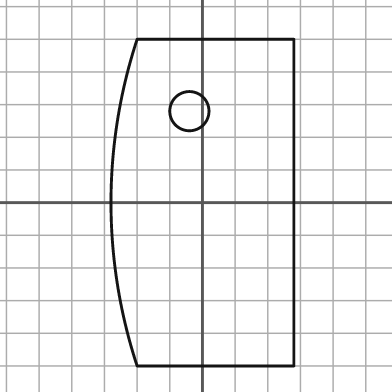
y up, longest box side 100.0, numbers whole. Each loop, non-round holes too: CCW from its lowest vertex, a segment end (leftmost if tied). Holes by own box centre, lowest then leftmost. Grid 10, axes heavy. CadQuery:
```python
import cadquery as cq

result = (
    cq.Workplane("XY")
    .moveTo(-20.0, -50.0)
    .lineTo(28.0, -50.0)
    .lineTo(28.0, 50.0)
    .lineTo(-20.0, 50.0)
    .threePointArc((-28.0, 0.0), (-20.0, -50.0))
    .close()
    .moveTo(-4.0, 28.0)
    .circle(6.0)
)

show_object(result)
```